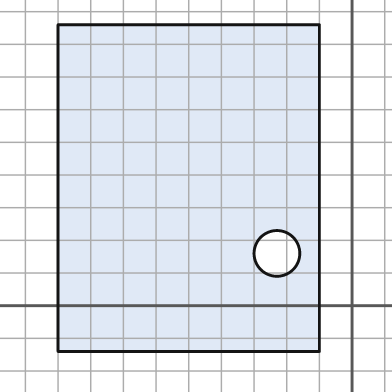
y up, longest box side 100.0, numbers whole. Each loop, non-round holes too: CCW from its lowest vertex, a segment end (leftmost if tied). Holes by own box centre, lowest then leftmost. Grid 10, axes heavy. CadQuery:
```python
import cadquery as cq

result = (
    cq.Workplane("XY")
    .moveTo(-90.0, -14.0)
    .lineTo(-10.0, -14.0)
    .lineTo(-10.0, 86.0)
    .lineTo(-90.0, 86.0)
    .close()
    .moveTo(-23.0, 16.0)
    .circle(7.0)
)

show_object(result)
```